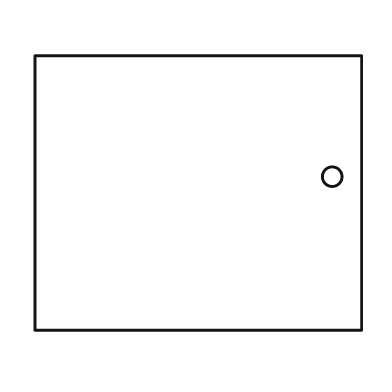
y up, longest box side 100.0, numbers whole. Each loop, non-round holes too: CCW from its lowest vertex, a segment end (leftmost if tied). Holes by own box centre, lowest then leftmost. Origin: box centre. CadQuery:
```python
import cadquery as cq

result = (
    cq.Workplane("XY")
    .moveTo(-50.0, -42.0)
    .lineTo(50.0, -42.0)
    .lineTo(50.0, 42.0)
    .lineTo(-50.0, 42.0)
    .close()
    .moveTo(41.0, 5.0)
    .circle(3.0)
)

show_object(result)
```